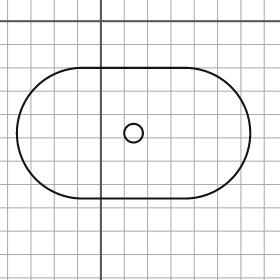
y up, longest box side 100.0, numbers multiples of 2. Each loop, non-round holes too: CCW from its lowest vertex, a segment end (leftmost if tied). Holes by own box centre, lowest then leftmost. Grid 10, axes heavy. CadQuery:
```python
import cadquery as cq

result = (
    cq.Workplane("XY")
    .moveTo(-8.0, -76.0)
    .lineTo(36.0, -76.0)
    .threePointArc((64.0, -48.0), (36.0, -20.0))
    .lineTo(-8.0, -20.0)
    .threePointArc((-36.0, -48.0), (-8.0, -76.0))
    .close()
    .moveTo(14.0, -48.0)
    .circle(4.0)
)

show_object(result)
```